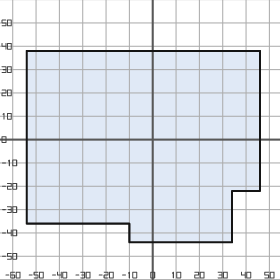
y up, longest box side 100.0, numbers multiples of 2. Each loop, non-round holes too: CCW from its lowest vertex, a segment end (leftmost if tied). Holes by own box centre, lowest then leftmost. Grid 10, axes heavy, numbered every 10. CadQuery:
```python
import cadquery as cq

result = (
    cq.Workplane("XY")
    .moveTo(-10.0, -44.0)
    .lineTo(34.0, -44.0)
    .lineTo(34.0, -22.0)
    .lineTo(46.0, -22.0)
    .lineTo(46.0, 38.0)
    .lineTo(-54.0, 38.0)
    .lineTo(-54.0, -36.0)
    .lineTo(-10.0, -36.0)
    .close()
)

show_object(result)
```